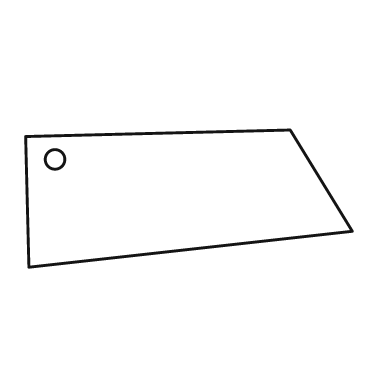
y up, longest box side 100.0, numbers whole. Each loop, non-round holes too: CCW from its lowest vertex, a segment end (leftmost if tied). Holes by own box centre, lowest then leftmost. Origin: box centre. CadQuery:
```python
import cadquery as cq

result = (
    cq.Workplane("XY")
    .moveTo(-49.0, -21.0)
    .lineTo(50.0, -10.0)
    .lineTo(31.0, 21.0)
    .lineTo(-50.0, 19.0)
    .close()
    .moveTo(-41.0, 12.0)
    .circle(3.0)
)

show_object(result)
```